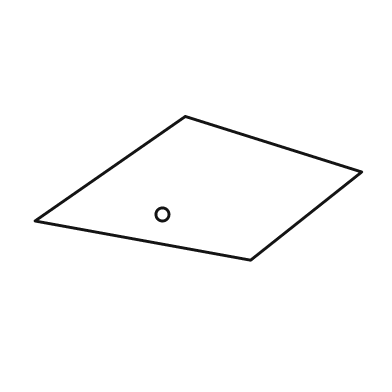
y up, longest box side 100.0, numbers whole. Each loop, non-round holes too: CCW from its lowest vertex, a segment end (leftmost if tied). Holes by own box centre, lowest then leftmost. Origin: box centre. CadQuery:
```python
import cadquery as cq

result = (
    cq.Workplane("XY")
    .moveTo(16.0, -22.0)
    .lineTo(50.0, 5.0)
    .lineTo(-4.0, 22.0)
    .lineTo(-50.0, -10.0)
    .close()
    .moveTo(-11.0, -8.0)
    .circle(2.0)
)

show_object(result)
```